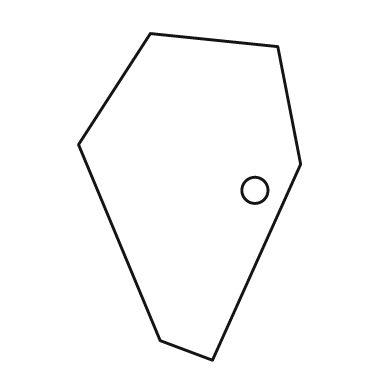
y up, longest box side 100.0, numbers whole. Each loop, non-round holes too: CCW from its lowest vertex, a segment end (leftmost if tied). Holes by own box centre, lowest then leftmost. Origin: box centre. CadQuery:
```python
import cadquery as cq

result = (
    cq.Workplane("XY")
    .moveTo(7.0, -50.0)
    .lineTo(34.0, 10.0)
    .lineTo(27.0, 46.0)
    .lineTo(-12.0, 50.0)
    .lineTo(-34.0, 16.0)
    .lineTo(-9.0, -44.0)
    .close()
    .moveTo(20.0, 2.0)
    .circle(4.0)
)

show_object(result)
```